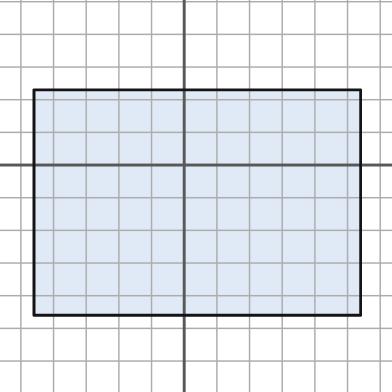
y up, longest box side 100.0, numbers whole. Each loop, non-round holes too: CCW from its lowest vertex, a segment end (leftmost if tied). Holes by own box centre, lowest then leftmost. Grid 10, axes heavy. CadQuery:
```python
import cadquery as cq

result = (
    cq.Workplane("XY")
    .moveTo(-46.0, -46.0)
    .lineTo(54.0, -46.0)
    .lineTo(54.0, 23.0)
    .lineTo(-46.0, 23.0)
    .close()
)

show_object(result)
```